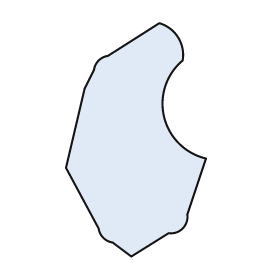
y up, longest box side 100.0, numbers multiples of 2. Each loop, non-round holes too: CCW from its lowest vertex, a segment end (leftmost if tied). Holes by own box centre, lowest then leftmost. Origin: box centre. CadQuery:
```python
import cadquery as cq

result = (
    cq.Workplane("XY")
    .moveTo(-2.0, -50.0)
    .lineTo(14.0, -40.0)
    .threePointArc((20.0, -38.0), (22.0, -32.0))
    .lineTo(30.0, -8.0)
    .threePointArc((12.0, 10.0), (20.0, 34.0))
    .threePointArc((18.0, 44.0), (10.0, 50.0))
    .lineTo(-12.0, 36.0)
    .threePointArc((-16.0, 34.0), (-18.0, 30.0))
    .lineTo(-22.0, 22.0)
    .lineTo(-30.0, -12.0)
    .lineTo(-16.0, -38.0)
    .threePointArc((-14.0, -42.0), (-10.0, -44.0))
    .close()
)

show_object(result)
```